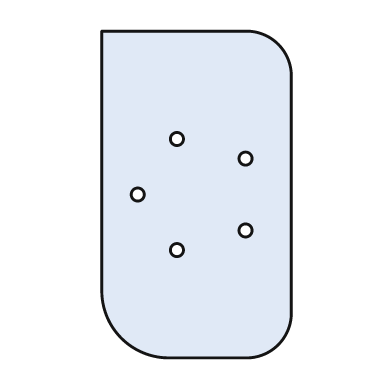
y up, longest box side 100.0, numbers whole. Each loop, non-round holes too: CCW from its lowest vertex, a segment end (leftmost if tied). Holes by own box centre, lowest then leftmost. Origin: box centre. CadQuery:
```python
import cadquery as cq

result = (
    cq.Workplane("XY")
    .moveTo(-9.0, -50.0)
    .lineTo(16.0, -50.0)
    .threePointArc((25.0, -46.0), (29.0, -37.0))
    .lineTo(29.0, 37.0)
    .threePointArc((25.0, 46.0), (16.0, 50.0))
    .lineTo(-29.0, 50.0)
    .lineTo(-29.0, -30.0)
    .threePointArc((-23.0, -44.0), (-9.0, -50.0))
    .close()
    .moveTo(-6.0, -17.0)
    .circle(2.0)
    .moveTo(15.0, -11.0)
    .circle(2.0)
    .moveTo(-18.0, 0.0)
    .circle(2.0)
    .moveTo(15.0, 11.0)
    .circle(2.0)
    .moveTo(-6.0, 17.0)
    .circle(2.0)
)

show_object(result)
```